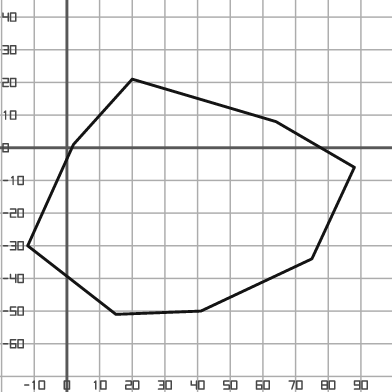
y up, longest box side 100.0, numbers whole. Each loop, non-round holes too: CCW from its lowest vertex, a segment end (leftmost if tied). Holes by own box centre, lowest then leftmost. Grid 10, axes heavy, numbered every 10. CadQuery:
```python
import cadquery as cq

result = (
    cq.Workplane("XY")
    .moveTo(15.0, -51.0)
    .lineTo(41.0, -50.0)
    .lineTo(75.0, -34.0)
    .lineTo(88.0, -6.0)
    .lineTo(64.0, 8.0)
    .lineTo(20.0, 21.0)
    .lineTo(2.0, 1.0)
    .lineTo(-12.0, -30.0)
    .close()
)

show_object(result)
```